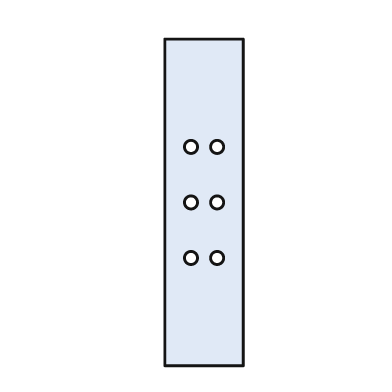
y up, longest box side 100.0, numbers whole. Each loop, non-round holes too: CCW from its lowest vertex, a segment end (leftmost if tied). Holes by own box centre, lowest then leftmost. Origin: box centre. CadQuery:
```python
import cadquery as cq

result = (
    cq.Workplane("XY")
    .moveTo(-12.0, -50.0)
    .lineTo(12.0, -50.0)
    .lineTo(12.0, 50.0)
    .lineTo(-12.0, 50.0)
    .close()
    .moveTo(-4.0, -17.0)
    .circle(2.0)
    .moveTo(4.0, -17.0)
    .circle(2.0)
    .moveTo(-4.0, 0.0)
    .circle(2.0)
    .moveTo(4.0, 0.0)
    .circle(2.0)
    .moveTo(-4.0, 17.0)
    .circle(2.0)
    .moveTo(4.0, 17.0)
    .circle(2.0)
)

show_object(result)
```